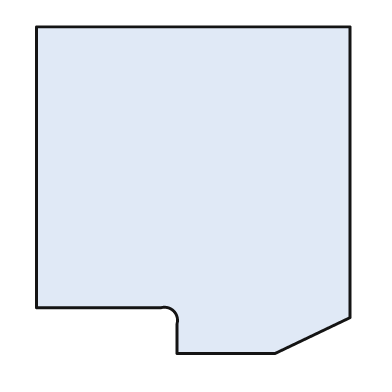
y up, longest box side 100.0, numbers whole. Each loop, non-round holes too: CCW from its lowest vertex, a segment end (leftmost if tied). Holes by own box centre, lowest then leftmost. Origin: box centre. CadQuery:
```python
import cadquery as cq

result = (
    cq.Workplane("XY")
    .moveTo(-5.0, -50.0)
    .lineTo(25.0, -50.0)
    .lineTo(48.0, -39.0)
    .lineTo(48.0, 50.0)
    .lineTo(-48.0, 50.0)
    .lineTo(-48.0, -36.0)
    .lineTo(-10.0, -36.0)
    .threePointArc((-6.0, -37.0), (-5.0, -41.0))
    .close()
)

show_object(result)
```